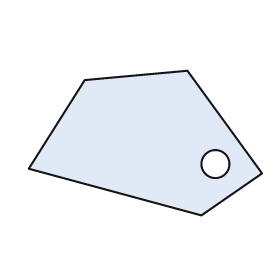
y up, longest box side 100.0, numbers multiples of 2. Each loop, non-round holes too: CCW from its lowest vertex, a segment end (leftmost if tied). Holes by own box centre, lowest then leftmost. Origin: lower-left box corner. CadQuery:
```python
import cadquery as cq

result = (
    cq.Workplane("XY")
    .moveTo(74.0, 0.0)
    .lineTo(100.0, 18.0)
    .lineTo(68.0, 62.0)
    .lineTo(24.0, 58.0)
    .lineTo(0.0, 20.0)
    .close()
    .moveTo(80.0, 22.0)
    .circle(6.0)
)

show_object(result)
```